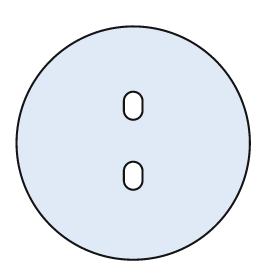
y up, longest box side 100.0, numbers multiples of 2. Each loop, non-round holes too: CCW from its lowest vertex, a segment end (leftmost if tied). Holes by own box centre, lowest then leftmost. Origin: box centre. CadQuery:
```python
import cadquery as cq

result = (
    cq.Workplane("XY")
    .moveTo(0.0, 0.0)
    .circle(50.0)
    .moveTo(-4.0, -16.0)
    .threePointArc((0.0, -20.0), (4.0, -16.0))
    .lineTo(4.0, -12.0)
    .threePointArc((0.0, -8.0), (-4.0, -12.0))
    .close()
    .moveTo(-4.0, 14.0)
    .threePointArc((0.0, 10.0), (4.0, 14.0))
    .lineTo(4.0, 18.0)
    .threePointArc((0.0, 22.0), (-4.0, 18.0))
    .close()
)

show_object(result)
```